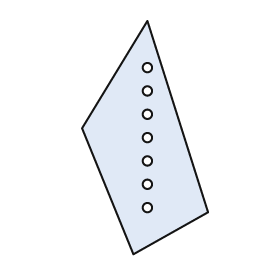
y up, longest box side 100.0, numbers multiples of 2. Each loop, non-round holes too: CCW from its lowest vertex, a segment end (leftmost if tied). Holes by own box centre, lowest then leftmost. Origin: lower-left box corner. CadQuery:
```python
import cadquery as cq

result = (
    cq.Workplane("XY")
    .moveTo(22.0, 0.0)
    .lineTo(54.0, 18.0)
    .lineTo(28.0, 100.0)
    .lineTo(0.0, 54.0)
    .close()
    .moveTo(28.0, 20.0)
    .circle(2.0)
    .moveTo(28.0, 30.0)
    .circle(2.0)
    .moveTo(28.0, 40.0)
    .circle(2.0)
    .moveTo(28.0, 50.0)
    .circle(2.0)
    .moveTo(28.0, 60.0)
    .circle(2.0)
    .moveTo(28.0, 70.0)
    .circle(2.0)
    .moveTo(28.0, 80.0)
    .circle(2.0)
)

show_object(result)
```